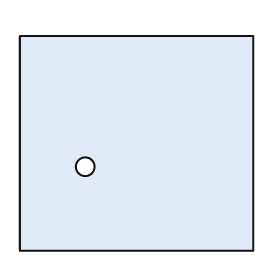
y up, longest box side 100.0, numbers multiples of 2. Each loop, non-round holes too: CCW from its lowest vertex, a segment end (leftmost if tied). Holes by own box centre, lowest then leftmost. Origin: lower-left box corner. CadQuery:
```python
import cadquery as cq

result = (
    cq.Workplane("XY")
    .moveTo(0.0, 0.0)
    .lineTo(100.0, 0.0)
    .lineTo(100.0, 92.0)
    .lineTo(0.0, 92.0)
    .close()
    .moveTo(28.0, 36.0)
    .circle(4.0)
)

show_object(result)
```